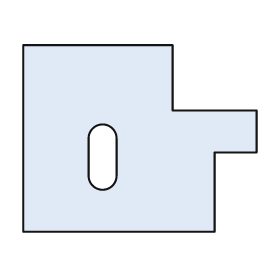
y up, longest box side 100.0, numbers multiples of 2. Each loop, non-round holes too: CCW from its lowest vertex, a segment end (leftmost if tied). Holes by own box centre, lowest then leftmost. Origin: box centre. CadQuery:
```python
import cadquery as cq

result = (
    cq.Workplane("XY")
    .moveTo(-50.0, -40.0)
    .lineTo(32.0, -40.0)
    .lineTo(32.0, -6.0)
    .lineTo(50.0, -6.0)
    .lineTo(50.0, 12.0)
    .lineTo(14.0, 12.0)
    .lineTo(14.0, 40.0)
    .lineTo(-50.0, 40.0)
    .close()
    .moveTo(-22.0, -16.0)
    .threePointArc((-16.0, -22.0), (-10.0, -16.0))
    .lineTo(-10.0, 0.0)
    .threePointArc((-16.0, 6.0), (-22.0, 0.0))
    .close()
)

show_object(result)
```